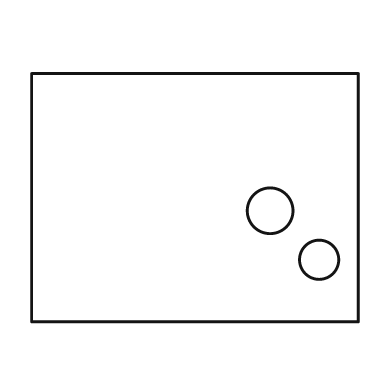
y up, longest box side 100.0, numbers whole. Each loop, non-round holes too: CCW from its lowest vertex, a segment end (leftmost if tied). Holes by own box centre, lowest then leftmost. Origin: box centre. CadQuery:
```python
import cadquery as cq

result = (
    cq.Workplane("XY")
    .moveTo(-50.0, -38.0)
    .lineTo(50.0, -38.0)
    .lineTo(50.0, 38.0)
    .lineTo(-50.0, 38.0)
    .close()
    .moveTo(38.0, -19.0)
    .circle(6.0)
    .moveTo(23.0, -4.0)
    .circle(7.0)
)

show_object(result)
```